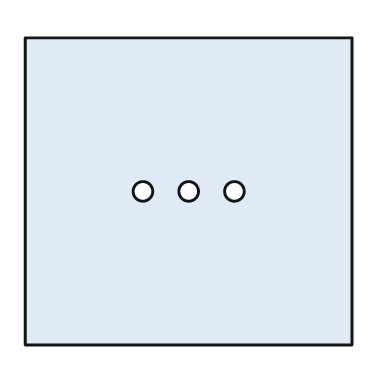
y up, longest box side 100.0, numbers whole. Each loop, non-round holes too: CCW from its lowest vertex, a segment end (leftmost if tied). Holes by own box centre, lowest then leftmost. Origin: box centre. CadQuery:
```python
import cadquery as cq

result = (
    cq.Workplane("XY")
    .moveTo(-50.0, -47.0)
    .lineTo(50.0, -47.0)
    .lineTo(50.0, 47.0)
    .lineTo(-50.0, 47.0)
    .close()
    .moveTo(-14.0, 0.0)
    .circle(3.0)
    .moveTo(0.0, 0.0)
    .circle(3.0)
    .moveTo(14.0, 0.0)
    .circle(3.0)
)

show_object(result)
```